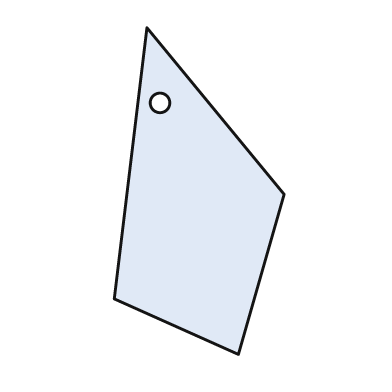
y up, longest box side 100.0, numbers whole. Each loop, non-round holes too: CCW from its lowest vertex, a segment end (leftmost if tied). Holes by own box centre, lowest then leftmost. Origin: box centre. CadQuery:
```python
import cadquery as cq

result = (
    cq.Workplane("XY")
    .moveTo(12.0, -50.0)
    .lineTo(26.0, -1.0)
    .lineTo(-16.0, 50.0)
    .lineTo(-26.0, -33.0)
    .close()
    .moveTo(-12.0, 27.0)
    .circle(3.0)
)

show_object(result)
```